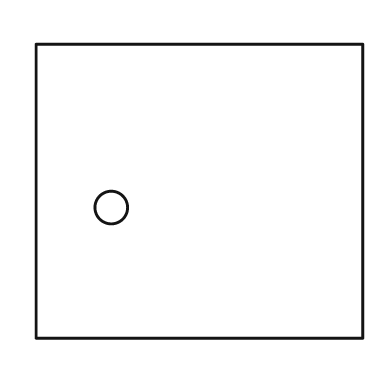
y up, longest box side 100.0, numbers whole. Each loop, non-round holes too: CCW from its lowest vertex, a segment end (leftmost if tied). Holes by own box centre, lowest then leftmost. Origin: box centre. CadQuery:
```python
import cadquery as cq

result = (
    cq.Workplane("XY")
    .moveTo(-50.0, -45.0)
    .lineTo(50.0, -45.0)
    .lineTo(50.0, 45.0)
    .lineTo(-50.0, 45.0)
    .close()
    .moveTo(-27.0, -5.0)
    .circle(5.0)
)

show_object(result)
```